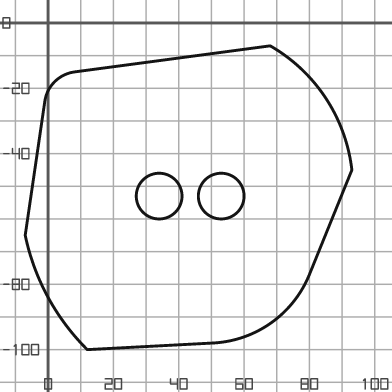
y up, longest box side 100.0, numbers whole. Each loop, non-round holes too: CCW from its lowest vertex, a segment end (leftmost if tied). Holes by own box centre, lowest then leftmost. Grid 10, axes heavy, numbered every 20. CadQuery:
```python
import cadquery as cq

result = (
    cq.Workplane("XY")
    .moveTo(12.0, -100.0)
    .lineTo(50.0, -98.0)
    .threePointArc((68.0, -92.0), (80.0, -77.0))
    .lineTo(93.0, -45.0)
    .threePointArc((85.0, -23.0), (68.0, -7.0))
    .lineTo(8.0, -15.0)
    .threePointArc((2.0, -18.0), (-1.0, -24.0))
    .lineTo(-7.0, -65.0)
    .threePointArc((0.0, -84.0), (12.0, -100.0))
    .close()
    .moveTo(34.0, -53.0)
    .circle(7.0)
    .moveTo(53.0, -53.0)
    .circle(7.0)
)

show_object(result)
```